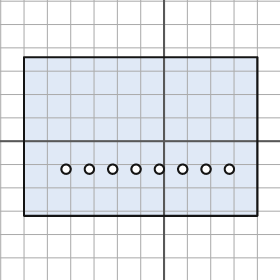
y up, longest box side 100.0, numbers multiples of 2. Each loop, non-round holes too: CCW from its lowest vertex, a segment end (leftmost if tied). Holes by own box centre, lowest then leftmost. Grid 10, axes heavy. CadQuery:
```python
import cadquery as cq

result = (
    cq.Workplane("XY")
    .moveTo(-60.0, -32.0)
    .lineTo(40.0, -32.0)
    .lineTo(40.0, 36.0)
    .lineTo(-60.0, 36.0)
    .close()
    .moveTo(-42.0, -12.0)
    .circle(2.0)
    .moveTo(-32.0, -12.0)
    .circle(2.0)
    .moveTo(-22.0, -12.0)
    .circle(2.0)
    .moveTo(-12.0, -12.0)
    .circle(2.0)
    .moveTo(-2.0, -12.0)
    .circle(2.0)
    .moveTo(8.0, -12.0)
    .circle(2.0)
    .moveTo(18.0, -12.0)
    .circle(2.0)
    .moveTo(28.0, -12.0)
    .circle(2.0)
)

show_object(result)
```